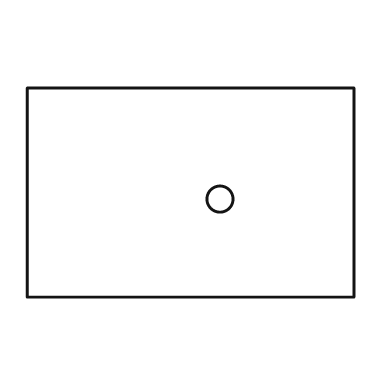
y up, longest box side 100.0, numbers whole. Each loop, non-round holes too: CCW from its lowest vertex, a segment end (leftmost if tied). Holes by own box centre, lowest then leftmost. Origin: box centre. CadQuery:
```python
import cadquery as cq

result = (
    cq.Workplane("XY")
    .moveTo(-50.0, -32.0)
    .lineTo(50.0, -32.0)
    .lineTo(50.0, 32.0)
    .lineTo(-50.0, 32.0)
    .close()
    .moveTo(9.0, -2.0)
    .circle(4.0)
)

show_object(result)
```